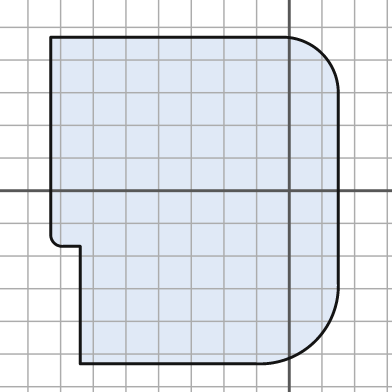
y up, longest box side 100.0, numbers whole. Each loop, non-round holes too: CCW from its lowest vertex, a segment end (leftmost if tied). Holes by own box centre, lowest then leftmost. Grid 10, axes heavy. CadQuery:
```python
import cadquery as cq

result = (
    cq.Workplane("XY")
    .moveTo(-64.0, -53.0)
    .lineTo(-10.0, -53.0)
    .threePointArc((8.0, -46.0), (15.0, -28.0))
    .lineTo(15.0, 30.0)
    .threePointArc((10.0, 42.0), (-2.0, 47.0))
    .lineTo(-73.0, 47.0)
    .lineTo(-73.0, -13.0)
    .threePointArc((-72.0, -16.0), (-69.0, -17.0))
    .lineTo(-64.0, -17.0)
    .close()
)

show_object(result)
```